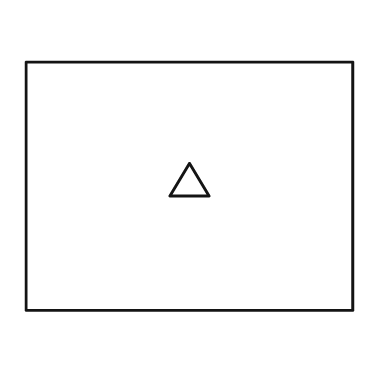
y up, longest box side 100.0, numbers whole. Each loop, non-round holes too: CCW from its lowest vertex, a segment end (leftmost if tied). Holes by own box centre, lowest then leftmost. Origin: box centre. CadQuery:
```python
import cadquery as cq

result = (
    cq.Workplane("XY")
    .moveTo(-50.0, -38.0)
    .lineTo(50.0, -38.0)
    .lineTo(50.0, 38.0)
    .lineTo(-50.0, 38.0)
    .close()
    .moveTo(-6.0, -3.0)
    .lineTo(6.0, -3.0)
    .lineTo(0.0, 7.0)
    .close()
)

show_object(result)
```